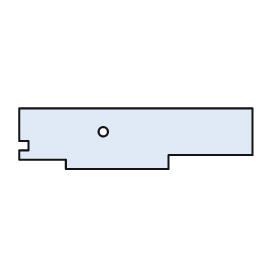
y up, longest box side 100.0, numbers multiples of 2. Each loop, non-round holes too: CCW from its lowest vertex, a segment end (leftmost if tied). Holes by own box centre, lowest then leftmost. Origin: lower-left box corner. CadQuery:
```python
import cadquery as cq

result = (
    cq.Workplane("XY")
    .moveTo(20.0, 0.0)
    .lineTo(64.0, 0.0)
    .lineTo(64.0, 6.0)
    .lineTo(100.0, 6.0)
    .lineTo(100.0, 26.0)
    .lineTo(0.0, 26.0)
    .lineTo(0.0, 12.0)
    .lineTo(4.0, 12.0)
    .lineTo(4.0, 8.0)
    .lineTo(0.0, 8.0)
    .lineTo(0.0, 4.0)
    .lineTo(20.0, 4.0)
    .close()
    .moveTo(36.0, 16.0)
    .circle(2.0)
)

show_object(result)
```